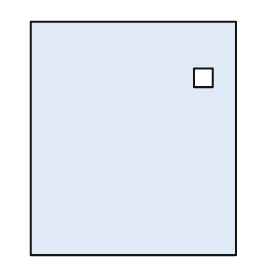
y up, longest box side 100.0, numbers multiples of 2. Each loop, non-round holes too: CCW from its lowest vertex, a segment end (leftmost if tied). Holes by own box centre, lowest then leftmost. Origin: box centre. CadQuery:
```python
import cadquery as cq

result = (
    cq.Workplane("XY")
    .moveTo(-44.0, -50.0)
    .lineTo(44.0, -50.0)
    .lineTo(44.0, 50.0)
    .lineTo(-44.0, 50.0)
    .close()
    .moveTo(26.0, 22.0)
    .lineTo(34.0, 22.0)
    .lineTo(34.0, 30.0)
    .lineTo(26.0, 30.0)
    .close()
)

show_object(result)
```